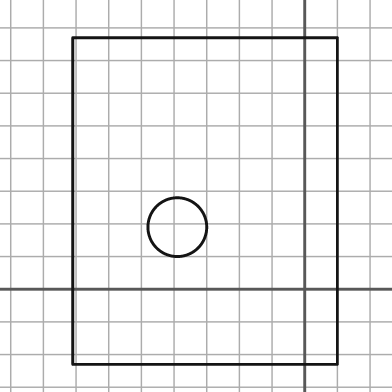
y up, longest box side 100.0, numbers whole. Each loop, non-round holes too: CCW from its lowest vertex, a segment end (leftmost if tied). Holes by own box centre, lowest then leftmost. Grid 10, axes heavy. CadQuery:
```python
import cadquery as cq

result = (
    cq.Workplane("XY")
    .moveTo(-71.0, -23.0)
    .lineTo(10.0, -23.0)
    .lineTo(10.0, 77.0)
    .lineTo(-71.0, 77.0)
    .close()
    .moveTo(-39.0, 19.0)
    .circle(9.0)
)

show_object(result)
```